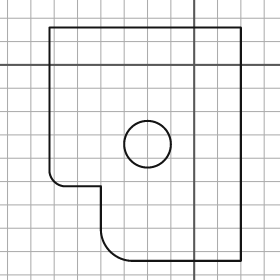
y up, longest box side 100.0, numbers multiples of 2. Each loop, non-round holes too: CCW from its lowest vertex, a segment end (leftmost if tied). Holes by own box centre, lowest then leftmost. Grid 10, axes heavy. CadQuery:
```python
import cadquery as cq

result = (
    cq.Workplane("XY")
    .moveTo(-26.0, -84.0)
    .lineTo(20.0, -84.0)
    .lineTo(20.0, 16.0)
    .lineTo(-62.0, 16.0)
    .lineTo(-62.0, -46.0)
    .threePointArc((-60.0, -50.0), (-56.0, -52.0))
    .lineTo(-40.0, -52.0)
    .lineTo(-40.0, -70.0)
    .threePointArc((-36.0, -80.0), (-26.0, -84.0))
    .close()
    .moveTo(-20.0, -34.0)
    .circle(10.0)
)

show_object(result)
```